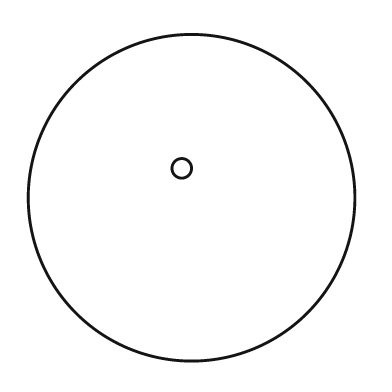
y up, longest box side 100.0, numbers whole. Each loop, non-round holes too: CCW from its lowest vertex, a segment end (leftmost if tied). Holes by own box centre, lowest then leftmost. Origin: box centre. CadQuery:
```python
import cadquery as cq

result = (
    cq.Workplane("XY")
    .moveTo(0.0, 0.0)
    .circle(50.0)
    .moveTo(-3.0, 9.0)
    .circle(3.0)
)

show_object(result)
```